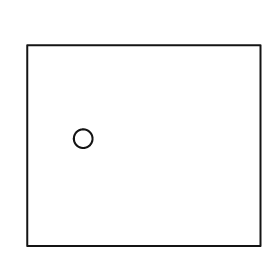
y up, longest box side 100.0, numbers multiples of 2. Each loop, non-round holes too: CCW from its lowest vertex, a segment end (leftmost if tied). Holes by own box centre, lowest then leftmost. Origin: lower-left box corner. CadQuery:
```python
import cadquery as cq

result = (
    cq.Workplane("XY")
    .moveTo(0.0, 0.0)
    .lineTo(100.0, 0.0)
    .lineTo(100.0, 86.0)
    .lineTo(0.0, 86.0)
    .close()
    .moveTo(24.0, 46.0)
    .circle(4.0)
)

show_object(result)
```